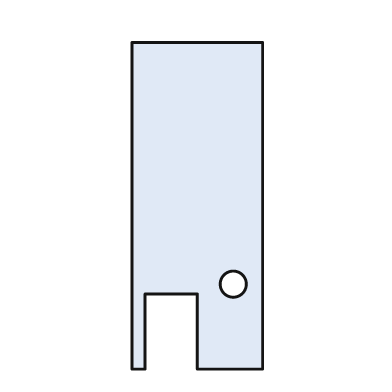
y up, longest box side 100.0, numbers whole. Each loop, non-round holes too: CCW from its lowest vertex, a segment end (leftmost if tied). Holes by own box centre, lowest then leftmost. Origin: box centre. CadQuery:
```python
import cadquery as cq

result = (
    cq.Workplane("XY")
    .moveTo(-20.0, -50.0)
    .lineTo(-16.0, -50.0)
    .lineTo(-16.0, -27.0)
    .lineTo(0.0, -27.0)
    .lineTo(0.0, -50.0)
    .lineTo(20.0, -50.0)
    .lineTo(20.0, 50.0)
    .lineTo(-20.0, 50.0)
    .close()
    .moveTo(11.0, -24.0)
    .circle(4.0)
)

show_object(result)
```